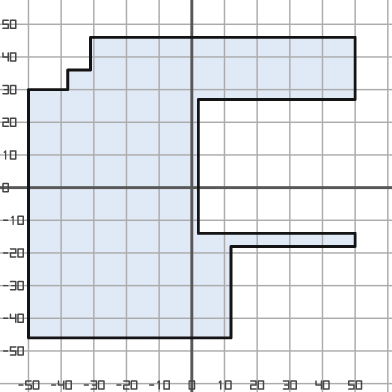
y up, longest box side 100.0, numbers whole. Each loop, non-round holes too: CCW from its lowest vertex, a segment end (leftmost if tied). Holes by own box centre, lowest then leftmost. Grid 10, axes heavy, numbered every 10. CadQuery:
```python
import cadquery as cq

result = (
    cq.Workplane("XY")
    .moveTo(-50.0, -46.0)
    .lineTo(12.0, -46.0)
    .lineTo(12.0, -18.0)
    .lineTo(50.0, -18.0)
    .lineTo(50.0, -14.0)
    .lineTo(2.0, -14.0)
    .lineTo(2.0, 27.0)
    .lineTo(50.0, 27.0)
    .lineTo(50.0, 46.0)
    .lineTo(-31.0, 46.0)
    .lineTo(-31.0, 36.0)
    .lineTo(-38.0, 36.0)
    .lineTo(-38.0, 30.0)
    .lineTo(-50.0, 30.0)
    .close()
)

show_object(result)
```